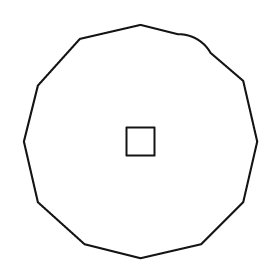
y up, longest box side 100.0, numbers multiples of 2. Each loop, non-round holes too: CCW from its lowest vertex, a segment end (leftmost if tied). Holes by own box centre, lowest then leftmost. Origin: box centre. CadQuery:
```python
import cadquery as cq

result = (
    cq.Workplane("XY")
    .moveTo(0.0, -50.0)
    .lineTo(26.0, -44.0)
    .lineTo(44.0, -26.0)
    .lineTo(50.0, 0.0)
    .lineTo(44.0, 26.0)
    .lineTo(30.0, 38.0)
    .threePointArc((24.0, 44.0), (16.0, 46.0))
    .lineTo(0.0, 50.0)
    .lineTo(-26.0, 44.0)
    .lineTo(-44.0, 24.0)
    .lineTo(-50.0, 0.0)
    .lineTo(-44.0, -26.0)
    .lineTo(-24.0, -44.0)
    .close()
    .moveTo(-6.0, -6.0)
    .lineTo(6.0, -6.0)
    .lineTo(6.0, 6.0)
    .lineTo(-6.0, 6.0)
    .close()
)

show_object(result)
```